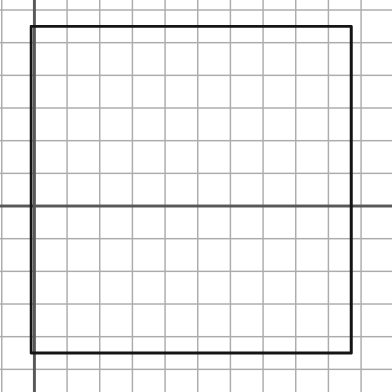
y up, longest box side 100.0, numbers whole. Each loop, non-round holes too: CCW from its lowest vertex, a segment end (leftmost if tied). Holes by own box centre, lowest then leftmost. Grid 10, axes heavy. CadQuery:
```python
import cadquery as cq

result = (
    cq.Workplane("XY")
    .moveTo(-1.0, -45.0)
    .lineTo(97.0, -45.0)
    .lineTo(97.0, 55.0)
    .lineTo(-1.0, 55.0)
    .close()
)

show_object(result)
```